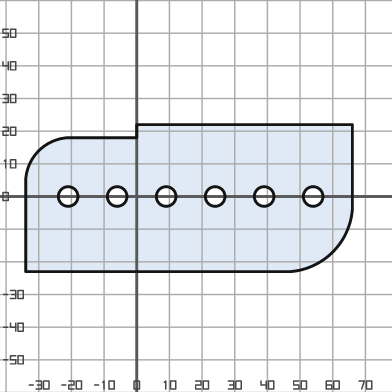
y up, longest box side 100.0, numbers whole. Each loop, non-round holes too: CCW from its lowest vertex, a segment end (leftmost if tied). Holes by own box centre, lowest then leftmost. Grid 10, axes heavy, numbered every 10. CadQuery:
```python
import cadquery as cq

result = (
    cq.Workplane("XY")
    .moveTo(-34.0, -23.0)
    .lineTo(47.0, -23.0)
    .threePointArc((60.0, -17.0), (66.0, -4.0))
    .lineTo(66.0, 22.0)
    .lineTo(0.0, 22.0)
    .lineTo(0.0, 18.0)
    .lineTo(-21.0, 18.0)
    .threePointArc((-30.0, 14.0), (-34.0, 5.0))
    .close()
    .moveTo(-21.0, 0.0)
    .circle(3.0)
    .moveTo(-6.0, 0.0)
    .circle(3.0)
    .moveTo(9.0, 0.0)
    .circle(3.0)
    .moveTo(24.0, 0.0)
    .circle(3.0)
    .moveTo(39.0, 0.0)
    .circle(3.0)
    .moveTo(54.0, 0.0)
    .circle(3.0)
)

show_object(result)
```